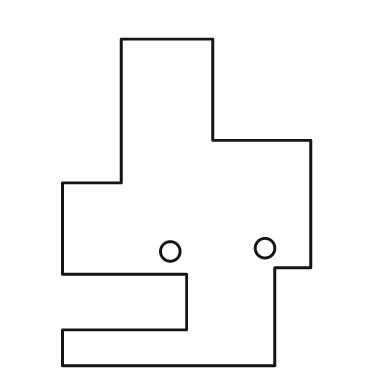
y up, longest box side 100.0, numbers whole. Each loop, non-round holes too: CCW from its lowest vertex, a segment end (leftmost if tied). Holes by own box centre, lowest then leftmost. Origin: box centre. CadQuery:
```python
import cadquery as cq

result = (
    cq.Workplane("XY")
    .moveTo(-38.0, -50.0)
    .lineTo(27.0, -50.0)
    .lineTo(27.0, -20.0)
    .lineTo(38.0, -20.0)
    .lineTo(38.0, 19.0)
    .lineTo(8.0, 19.0)
    .lineTo(8.0, 50.0)
    .lineTo(-20.0, 50.0)
    .lineTo(-20.0, 6.0)
    .lineTo(-38.0, 6.0)
    .lineTo(-38.0, -22.0)
    .lineTo(0.0, -22.0)
    .lineTo(0.0, -39.0)
    .lineTo(-38.0, -39.0)
    .close()
    .moveTo(-5.0, -15.0)
    .circle(3.0)
    .moveTo(24.0, -14.0)
    .circle(3.0)
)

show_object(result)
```